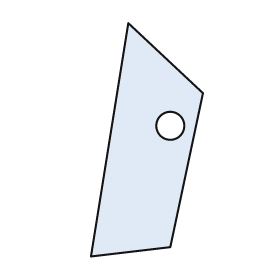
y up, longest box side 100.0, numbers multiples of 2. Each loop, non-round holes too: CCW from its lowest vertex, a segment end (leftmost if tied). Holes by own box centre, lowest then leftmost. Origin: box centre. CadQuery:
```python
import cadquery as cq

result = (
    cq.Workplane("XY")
    .moveTo(-24.0, -50.0)
    .lineTo(10.0, -46.0)
    .lineTo(24.0, 20.0)
    .lineTo(-8.0, 50.0)
    .close()
    .moveTo(10.0, 6.0)
    .circle(6.0)
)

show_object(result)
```